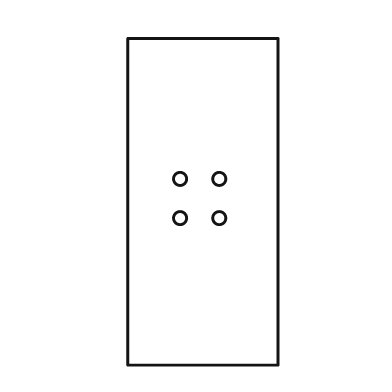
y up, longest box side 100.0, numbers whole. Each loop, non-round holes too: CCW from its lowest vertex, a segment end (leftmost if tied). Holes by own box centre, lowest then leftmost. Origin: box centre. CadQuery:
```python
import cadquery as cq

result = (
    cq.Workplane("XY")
    .moveTo(-23.0, -50.0)
    .lineTo(23.0, -50.0)
    .lineTo(23.0, 50.0)
    .lineTo(-23.0, 50.0)
    .close()
    .moveTo(-7.0, -5.0)
    .circle(2.0)
    .moveTo(5.0, -5.0)
    .circle(2.0)
    .moveTo(-7.0, 7.0)
    .circle(2.0)
    .moveTo(5.0, 7.0)
    .circle(2.0)
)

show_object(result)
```